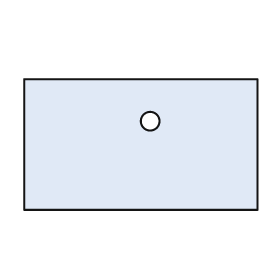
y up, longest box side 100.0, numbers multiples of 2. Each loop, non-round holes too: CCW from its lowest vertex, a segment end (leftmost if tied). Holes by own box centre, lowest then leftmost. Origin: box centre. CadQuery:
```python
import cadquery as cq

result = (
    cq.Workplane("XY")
    .moveTo(-50.0, -28.0)
    .lineTo(50.0, -28.0)
    .lineTo(50.0, 28.0)
    .lineTo(-50.0, 28.0)
    .close()
    .moveTo(4.0, 10.0)
    .circle(4.0)
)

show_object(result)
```